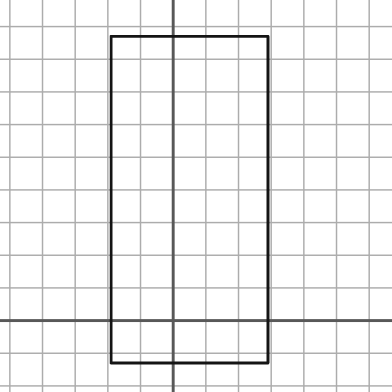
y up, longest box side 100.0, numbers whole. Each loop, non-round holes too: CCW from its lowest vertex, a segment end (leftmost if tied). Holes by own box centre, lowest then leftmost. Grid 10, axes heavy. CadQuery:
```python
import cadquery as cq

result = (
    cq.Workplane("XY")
    .moveTo(-19.0, -13.0)
    .lineTo(29.0, -13.0)
    .lineTo(29.0, 87.0)
    .lineTo(-19.0, 87.0)
    .close()
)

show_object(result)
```